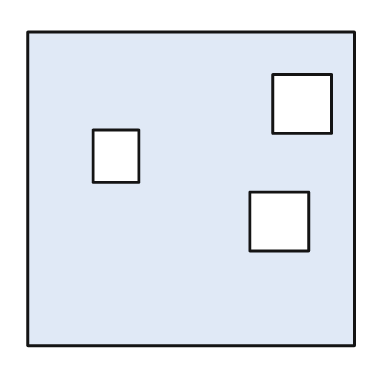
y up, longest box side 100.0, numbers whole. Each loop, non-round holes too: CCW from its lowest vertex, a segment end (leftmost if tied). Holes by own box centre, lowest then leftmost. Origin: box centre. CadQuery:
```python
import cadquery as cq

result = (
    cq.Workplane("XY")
    .moveTo(-50.0, -48.0)
    .lineTo(50.0, -48.0)
    .lineTo(50.0, 48.0)
    .lineTo(-50.0, 48.0)
    .close()
    .moveTo(18.0, -19.0)
    .lineTo(36.0, -19.0)
    .lineTo(36.0, -1.0)
    .lineTo(18.0, -1.0)
    .close()
    .moveTo(-30.0, 2.0)
    .lineTo(-16.0, 2.0)
    .lineTo(-16.0, 18.0)
    .lineTo(-30.0, 18.0)
    .close()
    .moveTo(25.0, 17.0)
    .lineTo(43.0, 17.0)
    .lineTo(43.0, 35.0)
    .lineTo(25.0, 35.0)
    .close()
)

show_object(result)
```